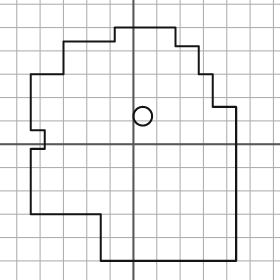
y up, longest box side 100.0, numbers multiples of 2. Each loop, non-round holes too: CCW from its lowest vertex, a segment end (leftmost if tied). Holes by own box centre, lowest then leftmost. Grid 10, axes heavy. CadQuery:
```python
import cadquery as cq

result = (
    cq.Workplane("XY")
    .moveTo(-14.0, -50.0)
    .lineTo(44.0, -50.0)
    .lineTo(44.0, 16.0)
    .lineTo(34.0, 16.0)
    .lineTo(34.0, 30.0)
    .lineTo(28.0, 30.0)
    .lineTo(28.0, 42.0)
    .lineTo(18.0, 42.0)
    .lineTo(18.0, 50.0)
    .lineTo(-8.0, 50.0)
    .lineTo(-8.0, 44.0)
    .lineTo(-30.0, 44.0)
    .lineTo(-30.0, 30.0)
    .lineTo(-44.0, 30.0)
    .lineTo(-44.0, 6.0)
    .lineTo(-38.0, 6.0)
    .lineTo(-38.0, -2.0)
    .lineTo(-44.0, -2.0)
    .lineTo(-44.0, -30.0)
    .lineTo(-14.0, -30.0)
    .close()
    .moveTo(4.0, 12.0)
    .circle(4.0)
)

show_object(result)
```